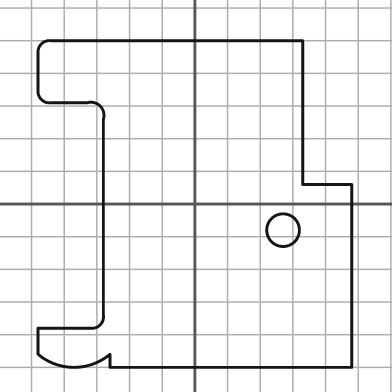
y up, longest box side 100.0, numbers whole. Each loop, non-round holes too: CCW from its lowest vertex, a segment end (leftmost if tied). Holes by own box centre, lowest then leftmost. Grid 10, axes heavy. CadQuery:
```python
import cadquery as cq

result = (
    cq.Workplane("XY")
    .moveTo(-26.0, -50.0)
    .lineTo(48.0, -50.0)
    .lineTo(48.0, 6.0)
    .lineTo(33.0, 6.0)
    .lineTo(33.0, 50.0)
    .lineTo(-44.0, 50.0)
    .threePointArc((-47.0, 49.0), (-48.0, 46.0))
    .lineTo(-48.0, 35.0)
    .threePointArc((-47.0, 32.0), (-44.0, 31.0))
    .lineTo(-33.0, 31.0)
    .threePointArc((-29.0, 30.0), (-28.0, 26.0))
    .lineTo(-28.0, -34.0)
    .threePointArc((-29.0, -37.0), (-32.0, -38.0))
    .lineTo(-48.0, -38.0)
    .lineTo(-48.0, -46.0)
    .threePointArc((-37.0, -50.0), (-26.0, -46.0))
    .close()
    .moveTo(27.0, -8.0)
    .circle(5.0)
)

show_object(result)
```